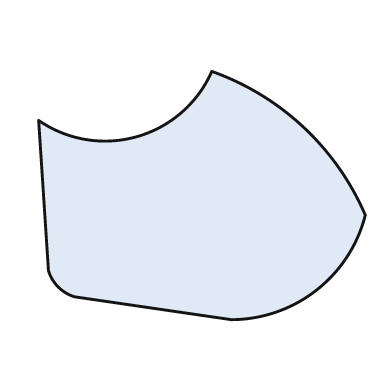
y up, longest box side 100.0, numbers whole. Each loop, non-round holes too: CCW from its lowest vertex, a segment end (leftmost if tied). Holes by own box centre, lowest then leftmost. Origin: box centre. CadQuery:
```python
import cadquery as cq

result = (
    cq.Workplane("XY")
    .moveTo(9.0, -38.0)
    .threePointArc((35.0, -29.0), (50.0, -6.0))
    .threePointArc((31.0, 21.0), (3.0, 38.0))
    .threePointArc((-20.0, 18.0), (-50.0, 23.0))
    .lineTo(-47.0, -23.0)
    .threePointArc((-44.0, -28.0), (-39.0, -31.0))
    .close()
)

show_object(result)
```